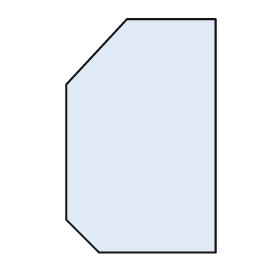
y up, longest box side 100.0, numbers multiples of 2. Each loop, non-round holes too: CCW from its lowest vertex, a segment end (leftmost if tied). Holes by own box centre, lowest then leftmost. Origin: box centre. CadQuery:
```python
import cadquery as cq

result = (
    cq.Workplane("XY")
    .moveTo(-18.0, -50.0)
    .lineTo(32.0, -50.0)
    .lineTo(32.0, 50.0)
    .lineTo(-6.0, 50.0)
    .lineTo(-32.0, 22.0)
    .lineTo(-32.0, -36.0)
    .close()
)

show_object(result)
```